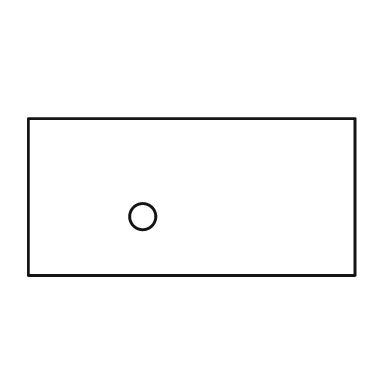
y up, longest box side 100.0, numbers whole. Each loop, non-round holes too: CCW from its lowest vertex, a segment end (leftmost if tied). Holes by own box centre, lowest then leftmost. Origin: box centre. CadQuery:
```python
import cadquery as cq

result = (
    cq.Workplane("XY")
    .moveTo(-50.0, -24.0)
    .lineTo(50.0, -24.0)
    .lineTo(50.0, 24.0)
    .lineTo(-50.0, 24.0)
    .close()
    .moveTo(-15.0, -6.0)
    .circle(4.0)
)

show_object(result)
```